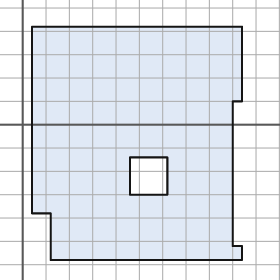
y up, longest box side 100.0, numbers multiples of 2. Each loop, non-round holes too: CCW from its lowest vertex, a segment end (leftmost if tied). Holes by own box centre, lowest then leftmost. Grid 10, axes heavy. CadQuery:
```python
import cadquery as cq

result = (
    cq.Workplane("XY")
    .moveTo(12.0, -58.0)
    .lineTo(94.0, -58.0)
    .lineTo(94.0, -52.0)
    .lineTo(90.0, -52.0)
    .lineTo(90.0, 10.0)
    .lineTo(94.0, 10.0)
    .lineTo(94.0, 42.0)
    .lineTo(4.0, 42.0)
    .lineTo(4.0, -38.0)
    .lineTo(12.0, -38.0)
    .close()
    .moveTo(46.0, -30.0)
    .lineTo(62.0, -30.0)
    .lineTo(62.0, -14.0)
    .lineTo(46.0, -14.0)
    .close()
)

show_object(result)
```